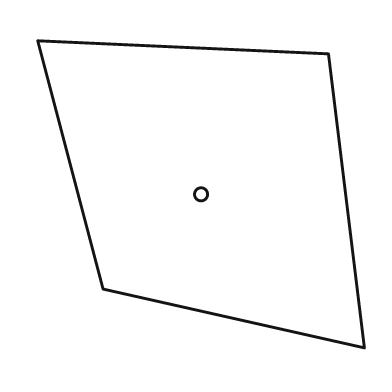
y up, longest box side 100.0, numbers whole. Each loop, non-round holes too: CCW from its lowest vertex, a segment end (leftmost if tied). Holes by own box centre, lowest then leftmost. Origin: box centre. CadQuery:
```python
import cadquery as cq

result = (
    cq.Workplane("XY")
    .moveTo(50.0, -47.0)
    .lineTo(39.0, 43.0)
    .lineTo(-50.0, 47.0)
    .lineTo(-30.0, -29.0)
    .close()
    .moveTo(0.0, 0.0)
    .circle(2.0)
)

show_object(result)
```